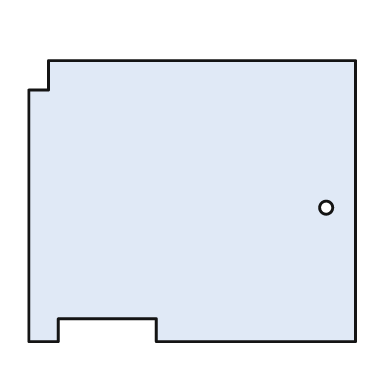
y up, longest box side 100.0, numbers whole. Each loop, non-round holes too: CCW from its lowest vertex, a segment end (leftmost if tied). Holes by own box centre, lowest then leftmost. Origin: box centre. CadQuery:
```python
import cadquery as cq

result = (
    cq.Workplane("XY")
    .moveTo(-50.0, -43.0)
    .lineTo(-41.0, -43.0)
    .lineTo(-41.0, -36.0)
    .lineTo(-11.0, -36.0)
    .lineTo(-11.0, -43.0)
    .lineTo(50.0, -43.0)
    .lineTo(50.0, 43.0)
    .lineTo(-44.0, 43.0)
    .lineTo(-44.0, 34.0)
    .lineTo(-50.0, 34.0)
    .close()
    .moveTo(41.0, -2.0)
    .circle(2.0)
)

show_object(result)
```